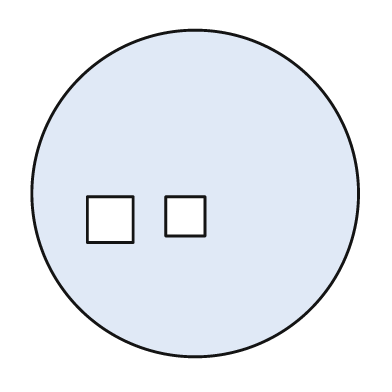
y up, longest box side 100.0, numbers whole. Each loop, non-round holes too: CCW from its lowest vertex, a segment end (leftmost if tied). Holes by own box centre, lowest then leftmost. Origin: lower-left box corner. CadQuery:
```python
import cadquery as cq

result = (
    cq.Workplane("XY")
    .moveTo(50.0, 50.0)
    .circle(50.0)
    .moveTo(17.0, 35.0)
    .lineTo(31.0, 35.0)
    .lineTo(31.0, 49.0)
    .lineTo(17.0, 49.0)
    .close()
    .moveTo(41.0, 37.0)
    .lineTo(53.0, 37.0)
    .lineTo(53.0, 49.0)
    .lineTo(41.0, 49.0)
    .close()
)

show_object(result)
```